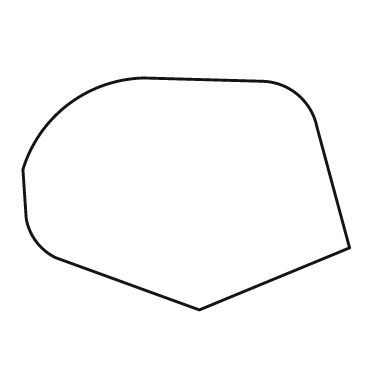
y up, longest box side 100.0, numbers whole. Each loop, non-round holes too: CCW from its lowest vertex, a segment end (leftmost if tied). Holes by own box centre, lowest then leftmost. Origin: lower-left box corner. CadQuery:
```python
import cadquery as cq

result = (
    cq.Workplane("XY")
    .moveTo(54.0, 0.0)
    .lineTo(100.0, 19.0)
    .lineTo(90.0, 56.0)
    .threePointArc((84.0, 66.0), (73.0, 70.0))
    .lineTo(37.0, 71.0)
    .threePointArc((14.0, 63.0), (0.0, 43.0))
    .lineTo(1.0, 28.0)
    .threePointArc((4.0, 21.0), (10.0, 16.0))
    .close()
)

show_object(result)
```